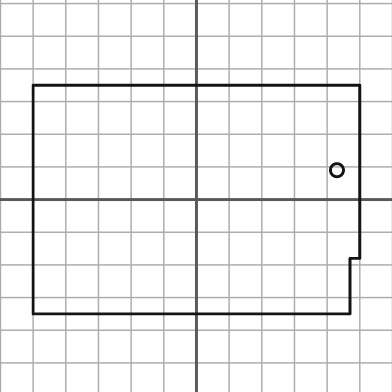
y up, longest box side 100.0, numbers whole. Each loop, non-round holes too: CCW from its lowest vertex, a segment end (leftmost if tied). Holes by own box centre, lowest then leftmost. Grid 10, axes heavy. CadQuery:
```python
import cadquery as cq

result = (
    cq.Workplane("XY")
    .moveTo(-50.0, -35.0)
    .lineTo(47.0, -35.0)
    .lineTo(47.0, -18.0)
    .lineTo(50.0, -18.0)
    .lineTo(50.0, 35.0)
    .lineTo(-50.0, 35.0)
    .close()
    .moveTo(43.0, 9.0)
    .circle(2.0)
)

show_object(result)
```